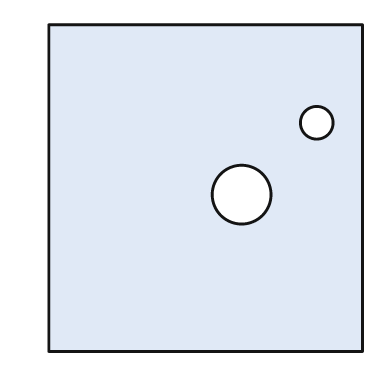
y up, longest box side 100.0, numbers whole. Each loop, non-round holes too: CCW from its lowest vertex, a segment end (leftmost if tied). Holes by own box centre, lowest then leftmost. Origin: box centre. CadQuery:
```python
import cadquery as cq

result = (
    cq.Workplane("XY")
    .moveTo(-48.0, -50.0)
    .lineTo(48.0, -50.0)
    .lineTo(48.0, 50.0)
    .lineTo(-48.0, 50.0)
    .close()
    .moveTo(11.0, -2.0)
    .circle(9.0)
    .moveTo(34.0, 20.0)
    .circle(5.0)
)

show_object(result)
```